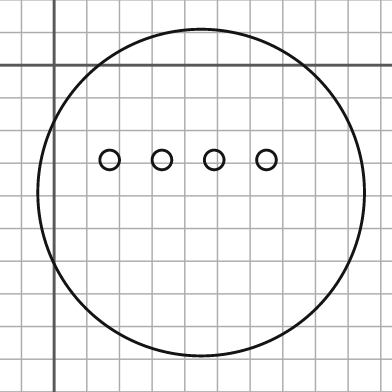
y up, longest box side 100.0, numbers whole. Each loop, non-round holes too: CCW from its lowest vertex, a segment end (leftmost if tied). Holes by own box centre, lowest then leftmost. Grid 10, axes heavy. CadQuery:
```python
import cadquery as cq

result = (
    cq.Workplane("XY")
    .moveTo(45.0, -39.0)
    .circle(50.0)
    .moveTo(17.0, -29.0)
    .circle(3.0)
    .moveTo(33.0, -29.0)
    .circle(3.0)
    .moveTo(49.0, -29.0)
    .circle(3.0)
    .moveTo(65.0, -29.0)
    .circle(3.0)
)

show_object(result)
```